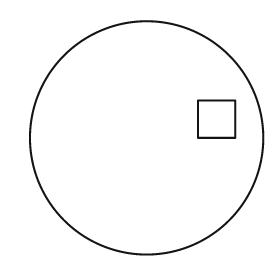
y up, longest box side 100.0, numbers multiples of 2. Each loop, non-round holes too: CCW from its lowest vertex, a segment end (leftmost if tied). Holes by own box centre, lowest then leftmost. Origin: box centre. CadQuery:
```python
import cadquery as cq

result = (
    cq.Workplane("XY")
    .moveTo(0.0, 0.0)
    .circle(50.0)
    .moveTo(22.0, 0.0)
    .lineTo(38.0, 0.0)
    .lineTo(38.0, 16.0)
    .lineTo(22.0, 16.0)
    .close()
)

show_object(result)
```